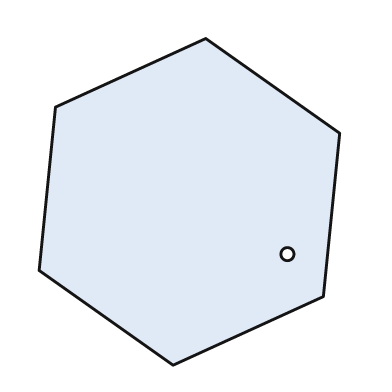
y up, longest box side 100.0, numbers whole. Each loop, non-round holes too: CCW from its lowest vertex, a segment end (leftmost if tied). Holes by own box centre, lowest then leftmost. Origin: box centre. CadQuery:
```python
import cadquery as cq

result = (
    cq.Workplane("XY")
    .moveTo(-5.0, -50.0)
    .lineTo(41.0, -29.0)
    .lineTo(46.0, 21.0)
    .lineTo(5.0, 50.0)
    .lineTo(-41.0, 29.0)
    .lineTo(-46.0, -21.0)
    .close()
    .moveTo(30.0, -16.0)
    .circle(2.0)
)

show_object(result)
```